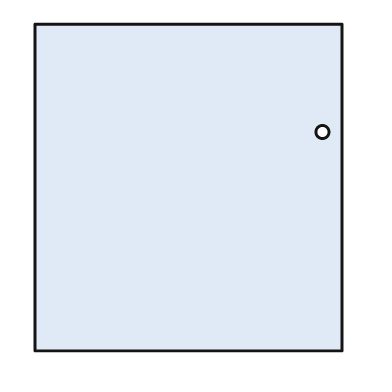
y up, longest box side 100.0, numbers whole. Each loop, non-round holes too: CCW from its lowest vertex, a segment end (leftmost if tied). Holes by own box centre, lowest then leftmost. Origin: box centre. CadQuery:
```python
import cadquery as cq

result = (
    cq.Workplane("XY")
    .moveTo(-47.0, -50.0)
    .lineTo(47.0, -50.0)
    .lineTo(47.0, 50.0)
    .lineTo(-47.0, 50.0)
    .close()
    .moveTo(41.0, 17.0)
    .circle(2.0)
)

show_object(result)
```